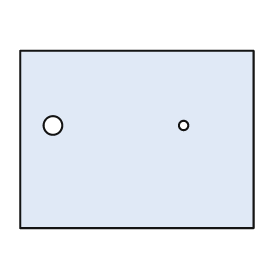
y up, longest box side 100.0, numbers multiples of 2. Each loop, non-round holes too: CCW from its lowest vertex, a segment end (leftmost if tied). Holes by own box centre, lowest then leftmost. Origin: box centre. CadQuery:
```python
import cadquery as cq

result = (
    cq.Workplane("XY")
    .moveTo(-50.0, -38.0)
    .lineTo(50.0, -38.0)
    .lineTo(50.0, 38.0)
    .lineTo(-50.0, 38.0)
    .close()
    .moveTo(-36.0, 6.0)
    .circle(4.0)
    .moveTo(20.0, 6.0)
    .circle(2.0)
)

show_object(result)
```